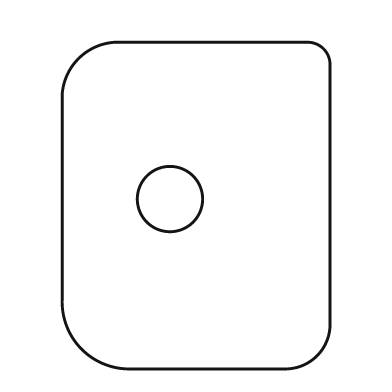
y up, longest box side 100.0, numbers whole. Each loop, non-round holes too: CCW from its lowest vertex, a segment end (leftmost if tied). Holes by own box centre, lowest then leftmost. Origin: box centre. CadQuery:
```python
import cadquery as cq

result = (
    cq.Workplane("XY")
    .moveTo(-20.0, -50.0)
    .lineTo(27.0, -50.0)
    .threePointArc((37.0, -46.0), (41.0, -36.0))
    .lineTo(41.0, 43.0)
    .threePointArc((39.0, 48.0), (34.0, 50.0))
    .lineTo(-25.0, 50.0)
    .threePointArc((-36.0, 45.0), (-41.0, 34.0))
    .lineTo(-41.0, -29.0)
    .threePointArc((-35.0, -44.0), (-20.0, -50.0))
    .close()
    .moveTo(-8.0, 2.0)
    .circle(10.0)
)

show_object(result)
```